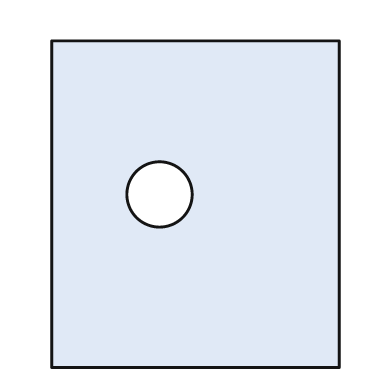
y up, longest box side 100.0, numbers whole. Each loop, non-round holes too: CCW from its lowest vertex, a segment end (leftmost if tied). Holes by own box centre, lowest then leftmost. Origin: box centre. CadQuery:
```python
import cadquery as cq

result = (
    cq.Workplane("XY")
    .moveTo(-44.0, -50.0)
    .lineTo(44.0, -50.0)
    .lineTo(44.0, 50.0)
    .lineTo(-44.0, 50.0)
    .close()
    .moveTo(-11.0, 3.0)
    .circle(10.0)
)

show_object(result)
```